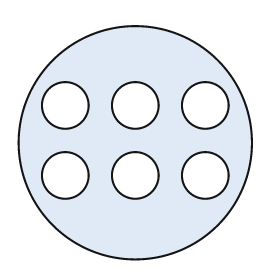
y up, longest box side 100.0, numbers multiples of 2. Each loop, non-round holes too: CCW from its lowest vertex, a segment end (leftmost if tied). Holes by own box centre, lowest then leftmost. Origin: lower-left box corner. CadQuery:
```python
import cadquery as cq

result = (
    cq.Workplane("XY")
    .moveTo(50.0, 50.0)
    .circle(50.0)
    .moveTo(20.0, 36.0)
    .circle(10.0)
    .moveTo(50.0, 36.0)
    .circle(10.0)
    .moveTo(80.0, 36.0)
    .circle(10.0)
    .moveTo(20.0, 66.0)
    .circle(10.0)
    .moveTo(50.0, 66.0)
    .circle(10.0)
    .moveTo(80.0, 66.0)
    .circle(10.0)
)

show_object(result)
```